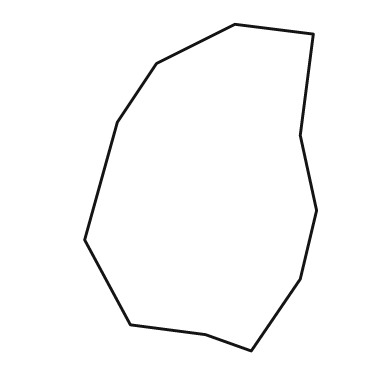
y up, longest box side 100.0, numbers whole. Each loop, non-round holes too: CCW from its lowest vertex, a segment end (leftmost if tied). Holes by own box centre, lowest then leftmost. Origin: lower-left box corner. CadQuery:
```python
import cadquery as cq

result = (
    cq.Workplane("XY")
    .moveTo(51.0, 0.0)
    .lineTo(66.0, 22.0)
    .lineTo(71.0, 43.0)
    .lineTo(66.0, 66.0)
    .lineTo(70.0, 97.0)
    .lineTo(46.0, 100.0)
    .lineTo(22.0, 88.0)
    .lineTo(10.0, 70.0)
    .lineTo(0.0, 34.0)
    .lineTo(14.0, 8.0)
    .lineTo(37.0, 5.0)
    .close()
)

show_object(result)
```